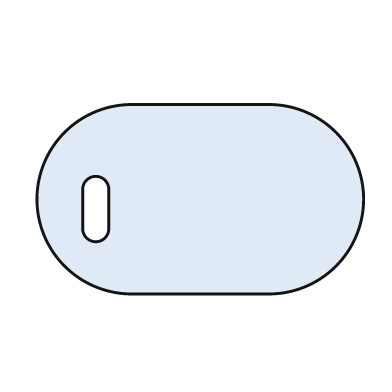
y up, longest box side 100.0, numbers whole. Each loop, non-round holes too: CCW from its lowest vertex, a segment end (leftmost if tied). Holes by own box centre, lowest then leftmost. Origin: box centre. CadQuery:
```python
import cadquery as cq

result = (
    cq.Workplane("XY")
    .moveTo(-21.0, -29.0)
    .lineTo(21.0, -29.0)
    .threePointArc((50.0, 0.0), (21.0, 29.0))
    .lineTo(-21.0, 29.0)
    .threePointArc((-50.0, 0.0), (-21.0, -29.0))
    .close()
    .moveTo(-36.0, -9.0)
    .threePointArc((-32.0, -13.0), (-28.0, -9.0))
    .lineTo(-28.0, 3.0)
    .threePointArc((-32.0, 7.0), (-36.0, 3.0))
    .close()
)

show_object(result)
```